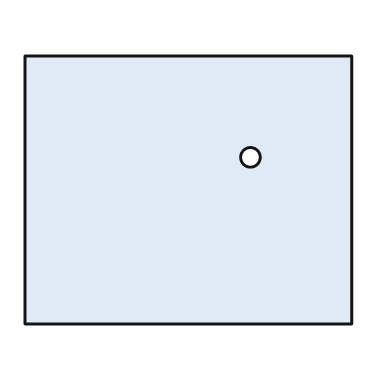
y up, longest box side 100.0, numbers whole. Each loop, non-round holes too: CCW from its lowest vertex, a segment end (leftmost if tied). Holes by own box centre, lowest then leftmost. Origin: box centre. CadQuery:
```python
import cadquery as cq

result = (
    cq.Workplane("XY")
    .moveTo(-50.0, -41.0)
    .lineTo(50.0, -41.0)
    .lineTo(50.0, 41.0)
    .lineTo(-50.0, 41.0)
    .close()
    .moveTo(19.0, 10.0)
    .circle(3.0)
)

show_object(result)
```